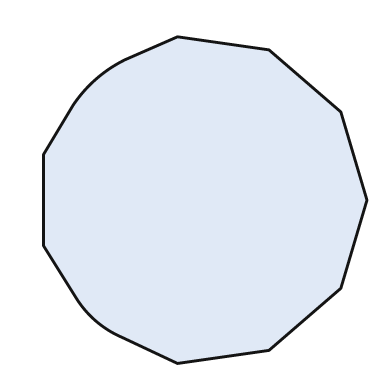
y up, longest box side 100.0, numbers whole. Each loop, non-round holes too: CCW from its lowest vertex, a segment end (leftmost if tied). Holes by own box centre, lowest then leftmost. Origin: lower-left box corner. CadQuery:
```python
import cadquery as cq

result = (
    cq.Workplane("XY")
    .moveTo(41.0, 0.0)
    .lineTo(69.0, 4.0)
    .lineTo(91.0, 23.0)
    .lineTo(99.0, 50.0)
    .lineTo(91.0, 77.0)
    .lineTo(69.0, 96.0)
    .lineTo(41.0, 100.0)
    .lineTo(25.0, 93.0)
    .threePointArc((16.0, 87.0), (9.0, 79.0))
    .lineTo(0.0, 64.0)
    .lineTo(0.0, 36.0)
    .lineTo(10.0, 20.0)
    .threePointArc((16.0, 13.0), (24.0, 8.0))
    .close()
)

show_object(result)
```